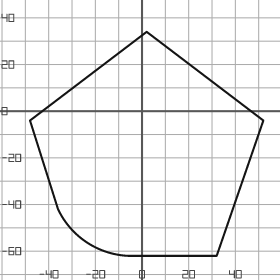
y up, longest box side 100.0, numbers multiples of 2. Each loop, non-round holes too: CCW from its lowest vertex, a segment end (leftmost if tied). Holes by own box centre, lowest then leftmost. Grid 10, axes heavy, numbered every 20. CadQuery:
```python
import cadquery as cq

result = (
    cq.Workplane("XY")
    .moveTo(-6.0, -62.0)
    .lineTo(32.0, -62.0)
    .lineTo(52.0, -4.0)
    .lineTo(2.0, 34.0)
    .lineTo(-48.0, -4.0)
    .lineTo(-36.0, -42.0)
    .threePointArc((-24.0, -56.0), (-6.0, -62.0))
    .close()
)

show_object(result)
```